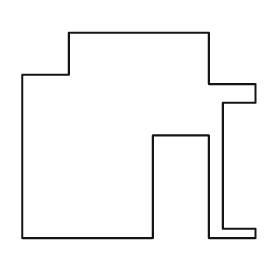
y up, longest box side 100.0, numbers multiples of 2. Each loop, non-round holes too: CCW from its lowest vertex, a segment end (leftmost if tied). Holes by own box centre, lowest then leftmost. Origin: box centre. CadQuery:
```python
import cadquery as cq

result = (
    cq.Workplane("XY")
    .moveTo(-50.0, -44.0)
    .lineTo(6.0, -44.0)
    .lineTo(6.0, 0.0)
    .lineTo(30.0, 0.0)
    .lineTo(30.0, -44.0)
    .lineTo(50.0, -44.0)
    .lineTo(50.0, -40.0)
    .lineTo(36.0, -40.0)
    .lineTo(36.0, 14.0)
    .lineTo(50.0, 14.0)
    .lineTo(50.0, 22.0)
    .lineTo(30.0, 22.0)
    .lineTo(30.0, 44.0)
    .lineTo(-30.0, 44.0)
    .lineTo(-30.0, 26.0)
    .lineTo(-50.0, 26.0)
    .close()
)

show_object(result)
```